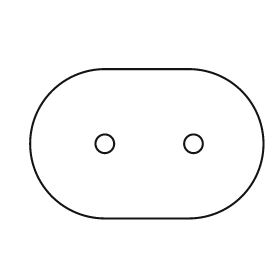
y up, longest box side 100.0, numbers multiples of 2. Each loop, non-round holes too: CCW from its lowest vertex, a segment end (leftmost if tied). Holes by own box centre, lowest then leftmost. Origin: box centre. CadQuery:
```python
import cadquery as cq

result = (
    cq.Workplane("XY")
    .moveTo(-18.0, -32.0)
    .lineTo(18.0, -32.0)
    .threePointArc((50.0, 0.0), (18.0, 32.0))
    .lineTo(-18.0, 32.0)
    .threePointArc((-50.0, 0.0), (-18.0, -32.0))
    .close()
    .moveTo(-18.0, 0.0)
    .circle(4.0)
    .moveTo(20.0, 0.0)
    .circle(4.0)
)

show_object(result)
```